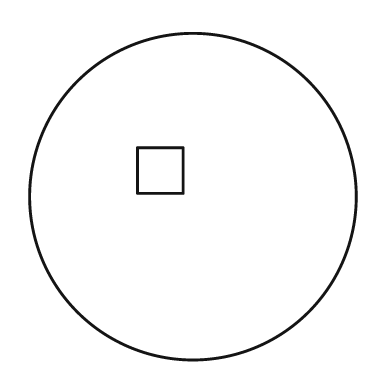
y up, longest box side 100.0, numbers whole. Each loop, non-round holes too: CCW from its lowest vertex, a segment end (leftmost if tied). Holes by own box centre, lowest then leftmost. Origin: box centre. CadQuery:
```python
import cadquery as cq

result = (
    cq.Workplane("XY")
    .moveTo(0.0, 0.0)
    .circle(50.0)
    .moveTo(-17.0, 1.0)
    .lineTo(-3.0, 1.0)
    .lineTo(-3.0, 15.0)
    .lineTo(-17.0, 15.0)
    .close()
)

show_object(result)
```